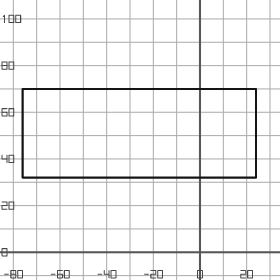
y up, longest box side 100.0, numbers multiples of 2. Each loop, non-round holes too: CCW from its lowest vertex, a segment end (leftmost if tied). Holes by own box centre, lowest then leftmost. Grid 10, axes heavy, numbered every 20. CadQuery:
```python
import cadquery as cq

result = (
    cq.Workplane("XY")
    .moveTo(-76.0, 32.0)
    .lineTo(24.0, 32.0)
    .lineTo(24.0, 70.0)
    .lineTo(-76.0, 70.0)
    .close()
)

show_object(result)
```